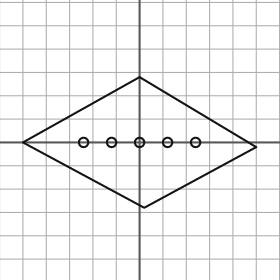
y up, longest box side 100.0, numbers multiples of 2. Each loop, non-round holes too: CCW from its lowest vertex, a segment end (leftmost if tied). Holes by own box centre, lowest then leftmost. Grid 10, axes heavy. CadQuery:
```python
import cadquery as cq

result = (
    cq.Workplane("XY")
    .moveTo(2.0, -28.0)
    .lineTo(50.0, -2.0)
    .lineTo(0.0, 28.0)
    .lineTo(-50.0, 0.0)
    .close()
    .moveTo(-24.0, 0.0)
    .circle(2.0)
    .moveTo(-12.0, 0.0)
    .circle(2.0)
    .moveTo(0.0, 0.0)
    .circle(2.0)
    .moveTo(12.0, 0.0)
    .circle(2.0)
    .moveTo(24.0, 0.0)
    .circle(2.0)
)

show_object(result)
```